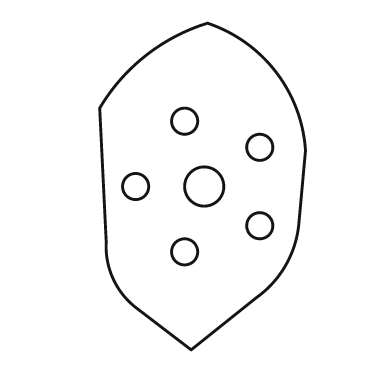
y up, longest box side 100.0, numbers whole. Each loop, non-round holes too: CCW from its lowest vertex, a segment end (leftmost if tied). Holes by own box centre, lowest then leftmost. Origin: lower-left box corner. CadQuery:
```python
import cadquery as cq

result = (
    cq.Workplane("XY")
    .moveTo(28.0, 0.0)
    .lineTo(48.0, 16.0)
    .threePointArc((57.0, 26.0), (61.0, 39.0))
    .lineTo(63.0, 61.0)
    .threePointArc((54.0, 85.0), (33.0, 100.0))
    .threePointArc((14.0, 90.0), (0.0, 74.0))
    .lineTo(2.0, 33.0)
    .threePointArc((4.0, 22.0), (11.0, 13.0))
    .close()
    .moveTo(26.0, 30.0)
    .circle(4.0)
    .moveTo(49.0, 38.0)
    .circle(4.0)
    .moveTo(11.0, 50.0)
    .circle(4.0)
    .moveTo(32.0, 50.0)
    .circle(6.0)
    .moveTo(49.0, 62.0)
    .circle(4.0)
    .moveTo(26.0, 70.0)
    .circle(4.0)
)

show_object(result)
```